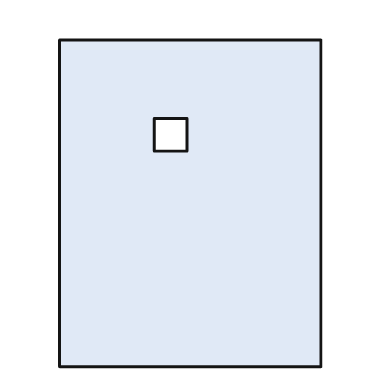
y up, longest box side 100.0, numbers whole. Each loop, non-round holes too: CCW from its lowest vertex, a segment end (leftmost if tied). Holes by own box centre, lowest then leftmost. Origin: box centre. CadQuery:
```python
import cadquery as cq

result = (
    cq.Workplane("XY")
    .moveTo(-40.0, -50.0)
    .lineTo(40.0, -50.0)
    .lineTo(40.0, 50.0)
    .lineTo(-40.0, 50.0)
    .close()
    .moveTo(-11.0, 16.0)
    .lineTo(-1.0, 16.0)
    .lineTo(-1.0, 26.0)
    .lineTo(-11.0, 26.0)
    .close()
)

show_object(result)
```